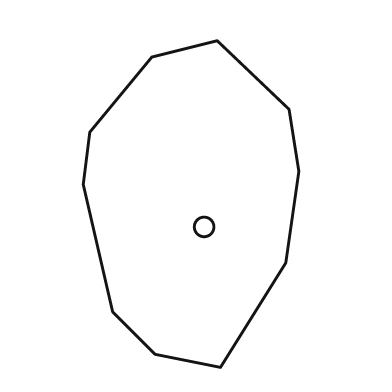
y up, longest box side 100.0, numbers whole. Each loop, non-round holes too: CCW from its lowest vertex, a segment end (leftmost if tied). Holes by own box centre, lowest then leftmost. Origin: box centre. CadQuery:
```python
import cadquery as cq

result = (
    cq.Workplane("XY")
    .moveTo(9.0, -50.0)
    .lineTo(29.0, -18.0)
    .lineTo(33.0, 10.0)
    .lineTo(30.0, 29.0)
    .lineTo(8.0, 50.0)
    .lineTo(-12.0, 45.0)
    .lineTo(-31.0, 22.0)
    .lineTo(-33.0, 6.0)
    .lineTo(-24.0, -33.0)
    .lineTo(-11.0, -46.0)
    .close()
    .moveTo(4.0, -7.0)
    .circle(3.0)
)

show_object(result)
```